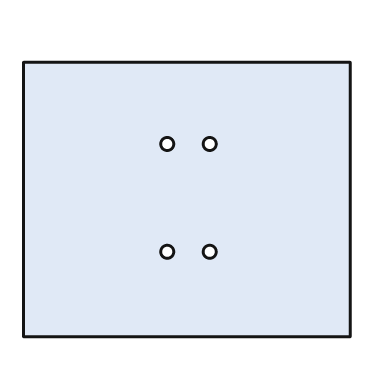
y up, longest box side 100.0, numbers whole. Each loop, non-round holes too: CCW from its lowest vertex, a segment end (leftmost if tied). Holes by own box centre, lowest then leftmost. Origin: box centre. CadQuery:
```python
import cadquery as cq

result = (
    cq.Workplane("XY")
    .moveTo(-50.0, -42.0)
    .lineTo(50.0, -42.0)
    .lineTo(50.0, 42.0)
    .lineTo(-50.0, 42.0)
    .close()
    .moveTo(-6.0, -16.0)
    .circle(2.0)
    .moveTo(7.0, -16.0)
    .circle(2.0)
    .moveTo(-6.0, 17.0)
    .circle(2.0)
    .moveTo(7.0, 17.0)
    .circle(2.0)
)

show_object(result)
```